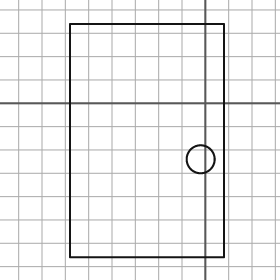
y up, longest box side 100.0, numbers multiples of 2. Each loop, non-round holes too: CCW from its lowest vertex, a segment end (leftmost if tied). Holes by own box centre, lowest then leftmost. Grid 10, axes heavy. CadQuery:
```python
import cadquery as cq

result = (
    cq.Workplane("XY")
    .moveTo(-58.0, -66.0)
    .lineTo(8.0, -66.0)
    .lineTo(8.0, 34.0)
    .lineTo(-58.0, 34.0)
    .close()
    .moveTo(-2.0, -24.0)
    .circle(6.0)
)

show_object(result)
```